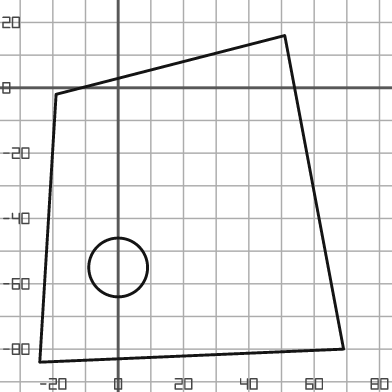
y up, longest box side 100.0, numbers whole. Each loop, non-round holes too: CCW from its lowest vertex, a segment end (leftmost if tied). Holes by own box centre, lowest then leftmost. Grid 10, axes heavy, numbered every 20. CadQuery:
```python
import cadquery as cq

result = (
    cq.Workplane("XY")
    .moveTo(-24.0, -84.0)
    .lineTo(69.0, -80.0)
    .lineTo(51.0, 16.0)
    .lineTo(-19.0, -2.0)
    .close()
    .moveTo(0.0, -55.0)
    .circle(9.0)
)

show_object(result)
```